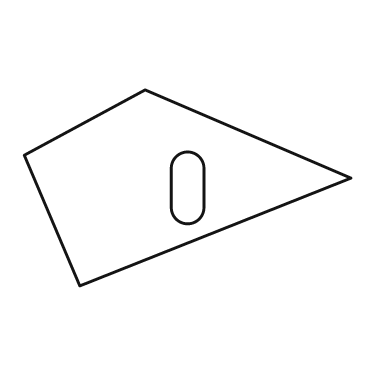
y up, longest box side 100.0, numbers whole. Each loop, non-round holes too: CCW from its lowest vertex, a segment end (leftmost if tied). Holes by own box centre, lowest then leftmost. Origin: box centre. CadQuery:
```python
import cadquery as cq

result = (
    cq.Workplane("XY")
    .moveTo(-33.0, -30.0)
    .lineTo(50.0, 3.0)
    .lineTo(-13.0, 30.0)
    .lineTo(-50.0, 10.0)
    .close()
    .moveTo(-5.0, -6.0)
    .threePointArc((0.0, -11.0), (5.0, -6.0))
    .lineTo(5.0, 6.0)
    .threePointArc((0.0, 11.0), (-5.0, 6.0))
    .close()
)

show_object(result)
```